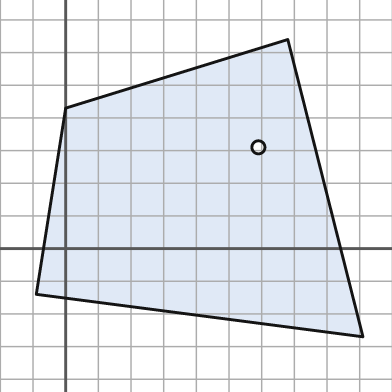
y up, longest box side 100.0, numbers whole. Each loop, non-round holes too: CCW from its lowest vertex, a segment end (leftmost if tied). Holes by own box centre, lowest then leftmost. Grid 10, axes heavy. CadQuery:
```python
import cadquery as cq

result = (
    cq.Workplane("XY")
    .moveTo(91.0, -27.0)
    .lineTo(68.0, 64.0)
    .lineTo(0.0, 43.0)
    .lineTo(-9.0, -14.0)
    .close()
    .moveTo(59.0, 31.0)
    .circle(2.0)
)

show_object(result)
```